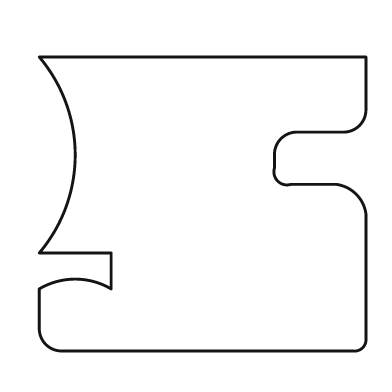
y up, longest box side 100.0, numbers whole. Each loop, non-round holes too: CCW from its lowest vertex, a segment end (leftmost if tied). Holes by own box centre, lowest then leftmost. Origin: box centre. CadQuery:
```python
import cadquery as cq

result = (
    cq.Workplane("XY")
    .moveTo(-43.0, -45.0)
    .lineTo(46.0, -45.0)
    .threePointArc((49.0, -44.0), (50.0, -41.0))
    .lineTo(50.0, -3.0)
    .threePointArc((47.0, 3.0), (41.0, 6.0))
    .lineTo(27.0, 6.0)
    .threePointArc((23.0, 7.0), (22.0, 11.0))
    .lineTo(22.0, 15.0)
    .threePointArc((24.0, 20.0), (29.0, 22.0))
    .lineTo(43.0, 22.0)
    .threePointArc((48.0, 24.0), (50.0, 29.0))
    .lineTo(50.0, 45.0)
    .lineTo(-50.0, 45.0)
    .threePointArc((-39.0, 15.0), (-50.0, -15.0))
    .lineTo(-28.0, -15.0)
    .lineTo(-28.0, -26.0)
    .threePointArc((-39.0, -23.0), (-50.0, -26.0))
    .lineTo(-50.0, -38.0)
    .threePointArc((-48.0, -43.0), (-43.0, -45.0))
    .close()
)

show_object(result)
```